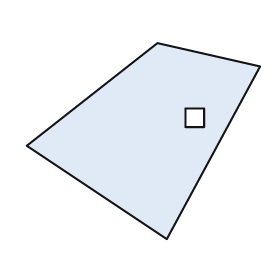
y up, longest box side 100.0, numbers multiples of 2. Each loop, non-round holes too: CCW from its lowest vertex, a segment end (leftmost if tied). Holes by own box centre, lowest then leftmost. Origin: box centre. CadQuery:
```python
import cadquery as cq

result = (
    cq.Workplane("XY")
    .moveTo(10.0, -42.0)
    .lineTo(50.0, 32.0)
    .lineTo(6.0, 42.0)
    .lineTo(-50.0, -2.0)
    .close()
    .moveTo(18.0, 6.0)
    .lineTo(26.0, 6.0)
    .lineTo(26.0, 14.0)
    .lineTo(18.0, 14.0)
    .close()
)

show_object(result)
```